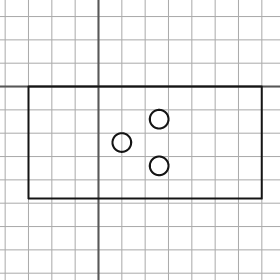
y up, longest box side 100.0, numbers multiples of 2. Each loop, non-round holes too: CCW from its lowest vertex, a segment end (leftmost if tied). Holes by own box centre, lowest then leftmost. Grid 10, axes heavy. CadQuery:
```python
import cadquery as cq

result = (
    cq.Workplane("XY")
    .moveTo(-30.0, -48.0)
    .lineTo(70.0, -48.0)
    .lineTo(70.0, 0.0)
    .lineTo(-30.0, 0.0)
    .close()
    .moveTo(26.0, -34.0)
    .circle(4.0)
    .moveTo(10.0, -24.0)
    .circle(4.0)
    .moveTo(26.0, -14.0)
    .circle(4.0)
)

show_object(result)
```